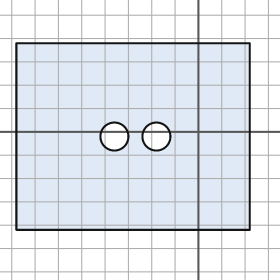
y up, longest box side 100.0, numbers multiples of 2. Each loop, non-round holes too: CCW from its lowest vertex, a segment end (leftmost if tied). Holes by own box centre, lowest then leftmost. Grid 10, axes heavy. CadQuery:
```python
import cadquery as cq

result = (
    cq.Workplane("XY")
    .moveTo(-78.0, -42.0)
    .lineTo(22.0, -42.0)
    .lineTo(22.0, 38.0)
    .lineTo(-78.0, 38.0)
    .close()
    .moveTo(-36.0, -2.0)
    .circle(6.0)
    .moveTo(-18.0, -2.0)
    .circle(6.0)
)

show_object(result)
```